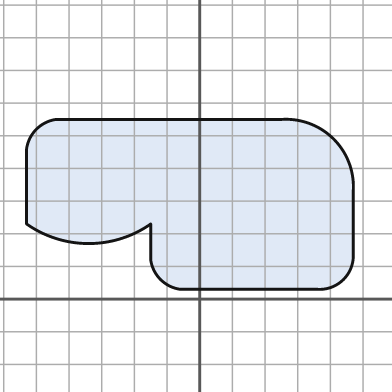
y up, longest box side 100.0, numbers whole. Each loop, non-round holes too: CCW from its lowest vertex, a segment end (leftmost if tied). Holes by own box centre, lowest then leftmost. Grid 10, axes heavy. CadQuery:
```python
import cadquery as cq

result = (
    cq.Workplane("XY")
    .moveTo(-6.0, 3.0)
    .lineTo(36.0, 3.0)
    .threePointArc((44.0, 6.0), (47.0, 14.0))
    .lineTo(47.0, 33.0)
    .threePointArc((41.0, 49.0), (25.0, 55.0))
    .lineTo(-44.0, 55.0)
    .threePointArc((-50.0, 52.0), (-53.0, 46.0))
    .lineTo(-53.0, 23.0)
    .threePointArc((-34.0, 17.0), (-15.0, 23.0))
    .lineTo(-15.0, 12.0)
    .threePointArc((-12.0, 6.0), (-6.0, 3.0))
    .close()
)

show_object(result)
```